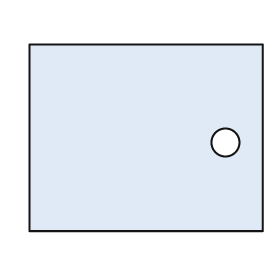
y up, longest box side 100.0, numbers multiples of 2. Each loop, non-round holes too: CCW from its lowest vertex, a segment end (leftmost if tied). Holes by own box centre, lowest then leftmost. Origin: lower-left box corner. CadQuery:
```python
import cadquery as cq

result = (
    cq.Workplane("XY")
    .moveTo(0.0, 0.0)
    .lineTo(100.0, 0.0)
    .lineTo(100.0, 80.0)
    .lineTo(0.0, 80.0)
    .close()
    .moveTo(84.0, 38.0)
    .circle(6.0)
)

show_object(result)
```